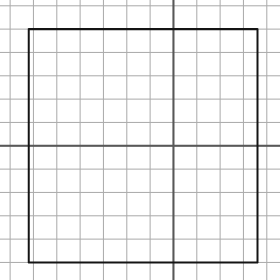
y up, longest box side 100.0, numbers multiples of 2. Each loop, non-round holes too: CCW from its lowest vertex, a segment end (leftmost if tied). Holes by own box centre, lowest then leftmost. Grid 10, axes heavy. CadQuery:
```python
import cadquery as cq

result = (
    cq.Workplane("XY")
    .moveTo(-62.0, -50.0)
    .lineTo(36.0, -50.0)
    .lineTo(36.0, 50.0)
    .lineTo(-62.0, 50.0)
    .close()
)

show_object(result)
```